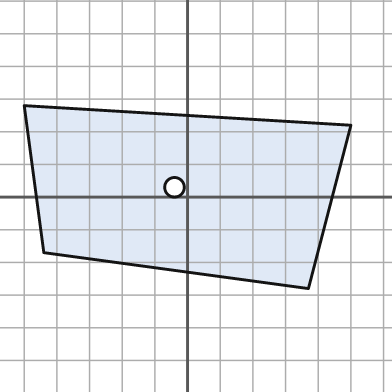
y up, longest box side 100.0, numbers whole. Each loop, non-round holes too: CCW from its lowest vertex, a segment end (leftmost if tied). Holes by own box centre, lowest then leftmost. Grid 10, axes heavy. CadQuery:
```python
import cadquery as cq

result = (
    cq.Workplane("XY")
    .moveTo(37.0, -28.0)
    .lineTo(50.0, 22.0)
    .lineTo(-50.0, 28.0)
    .lineTo(-44.0, -17.0)
    .close()
    .moveTo(-4.0, 3.0)
    .circle(3.0)
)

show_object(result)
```